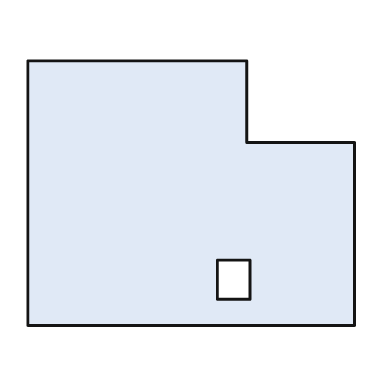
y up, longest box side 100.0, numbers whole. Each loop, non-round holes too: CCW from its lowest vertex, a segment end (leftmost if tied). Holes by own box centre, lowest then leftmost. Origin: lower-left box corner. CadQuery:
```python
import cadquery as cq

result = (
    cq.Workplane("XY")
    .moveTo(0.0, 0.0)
    .lineTo(100.0, 0.0)
    .lineTo(100.0, 56.0)
    .lineTo(67.0, 56.0)
    .lineTo(67.0, 81.0)
    .lineTo(0.0, 81.0)
    .close()
    .moveTo(58.0, 8.0)
    .lineTo(68.0, 8.0)
    .lineTo(68.0, 20.0)
    .lineTo(58.0, 20.0)
    .close()
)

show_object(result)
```